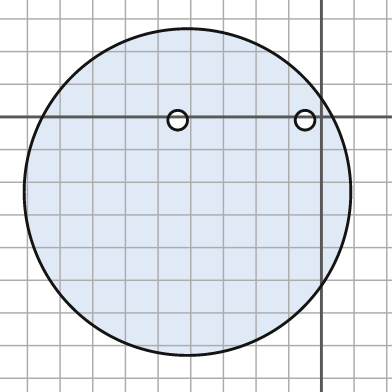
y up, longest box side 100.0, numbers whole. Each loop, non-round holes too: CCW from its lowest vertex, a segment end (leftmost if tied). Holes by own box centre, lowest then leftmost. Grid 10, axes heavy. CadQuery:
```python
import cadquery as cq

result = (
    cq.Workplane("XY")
    .moveTo(-41.0, -23.0)
    .circle(50.0)
    .moveTo(-44.0, -1.0)
    .circle(3.0)
    .moveTo(-5.0, -1.0)
    .circle(3.0)
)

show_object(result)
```